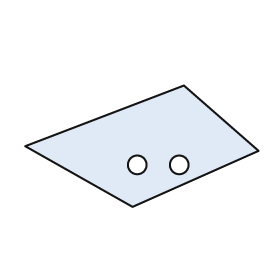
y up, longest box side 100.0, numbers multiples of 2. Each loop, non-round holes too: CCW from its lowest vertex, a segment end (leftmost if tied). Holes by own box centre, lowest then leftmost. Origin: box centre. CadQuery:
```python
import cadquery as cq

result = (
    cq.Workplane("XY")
    .moveTo(-4.0, -26.0)
    .lineTo(50.0, -2.0)
    .lineTo(18.0, 26.0)
    .lineTo(-50.0, 0.0)
    .close()
    .moveTo(-2.0, -8.0)
    .circle(4.0)
    .moveTo(16.0, -8.0)
    .circle(4.0)
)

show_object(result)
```